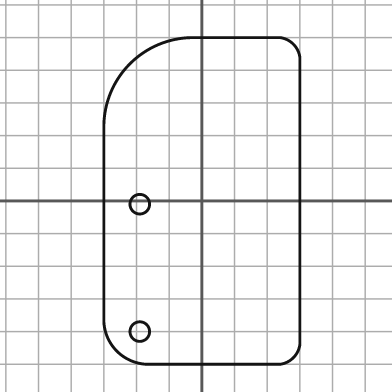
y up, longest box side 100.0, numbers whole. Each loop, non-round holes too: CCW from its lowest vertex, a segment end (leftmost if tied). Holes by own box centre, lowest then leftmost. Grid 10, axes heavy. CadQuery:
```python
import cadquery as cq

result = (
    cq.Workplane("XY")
    .moveTo(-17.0, -50.0)
    .lineTo(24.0, -50.0)
    .threePointArc((28.0, -48.0), (30.0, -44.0))
    .lineTo(30.0, 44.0)
    .threePointArc((28.0, 48.0), (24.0, 50.0))
    .lineTo(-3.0, 50.0)
    .threePointArc((-22.0, 42.0), (-30.0, 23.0))
    .lineTo(-30.0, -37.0)
    .threePointArc((-26.0, -46.0), (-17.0, -50.0))
    .close()
    .moveTo(-19.0, -40.0)
    .circle(3.0)
    .moveTo(-19.0, -1.0)
    .circle(3.0)
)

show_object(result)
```